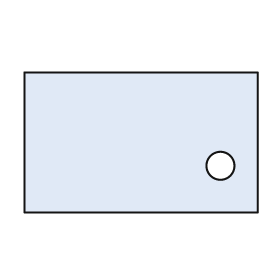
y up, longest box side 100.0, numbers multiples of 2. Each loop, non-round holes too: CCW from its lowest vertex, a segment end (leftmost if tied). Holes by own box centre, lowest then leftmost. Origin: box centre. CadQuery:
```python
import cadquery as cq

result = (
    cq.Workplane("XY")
    .moveTo(-50.0, -30.0)
    .lineTo(50.0, -30.0)
    .lineTo(50.0, 30.0)
    .lineTo(-50.0, 30.0)
    .close()
    .moveTo(34.0, -10.0)
    .circle(6.0)
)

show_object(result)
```